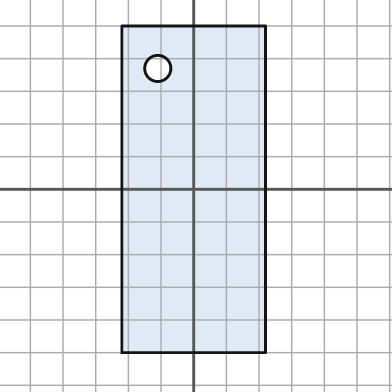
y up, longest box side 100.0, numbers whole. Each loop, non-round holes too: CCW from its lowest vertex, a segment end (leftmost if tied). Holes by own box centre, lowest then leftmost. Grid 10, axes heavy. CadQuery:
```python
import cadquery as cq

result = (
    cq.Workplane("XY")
    .moveTo(-22.0, -50.0)
    .lineTo(22.0, -50.0)
    .lineTo(22.0, 50.0)
    .lineTo(-22.0, 50.0)
    .close()
    .moveTo(-11.0, 37.0)
    .circle(4.0)
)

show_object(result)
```